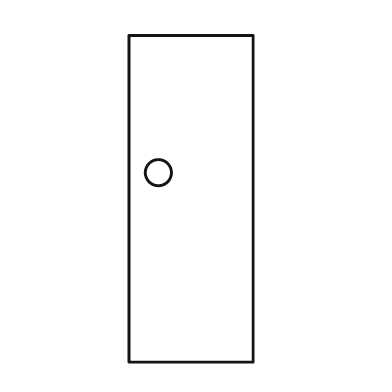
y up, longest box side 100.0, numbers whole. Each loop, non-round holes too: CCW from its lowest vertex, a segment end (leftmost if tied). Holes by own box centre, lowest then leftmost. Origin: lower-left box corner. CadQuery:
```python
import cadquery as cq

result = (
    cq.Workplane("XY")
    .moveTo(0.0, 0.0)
    .lineTo(38.0, 0.0)
    .lineTo(38.0, 100.0)
    .lineTo(0.0, 100.0)
    .close()
    .moveTo(9.0, 58.0)
    .circle(4.0)
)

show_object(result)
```